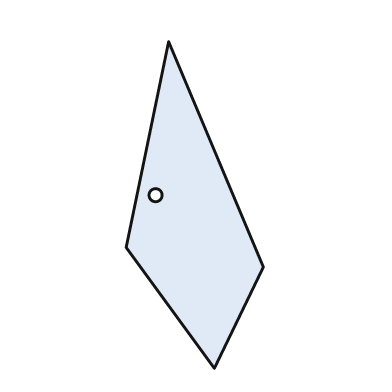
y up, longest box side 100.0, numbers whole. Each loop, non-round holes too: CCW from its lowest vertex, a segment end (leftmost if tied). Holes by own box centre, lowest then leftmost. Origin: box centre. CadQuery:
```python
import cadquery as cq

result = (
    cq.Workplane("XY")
    .moveTo(6.0, -50.0)
    .lineTo(21.0, -19.0)
    .lineTo(-8.0, 50.0)
    .lineTo(-21.0, -13.0)
    .close()
    .moveTo(-12.0, 3.0)
    .circle(2.0)
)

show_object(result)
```